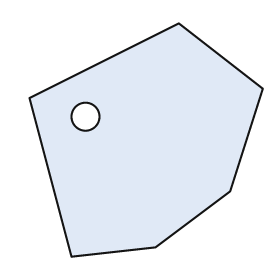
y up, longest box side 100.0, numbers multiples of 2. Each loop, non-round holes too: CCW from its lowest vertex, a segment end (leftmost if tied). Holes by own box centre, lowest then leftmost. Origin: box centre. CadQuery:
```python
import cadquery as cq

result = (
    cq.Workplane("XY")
    .moveTo(-32.0, -50.0)
    .lineTo(4.0, -46.0)
    .lineTo(36.0, -22.0)
    .lineTo(50.0, 22.0)
    .lineTo(14.0, 50.0)
    .lineTo(-50.0, 18.0)
    .close()
    .moveTo(-26.0, 10.0)
    .circle(6.0)
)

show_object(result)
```